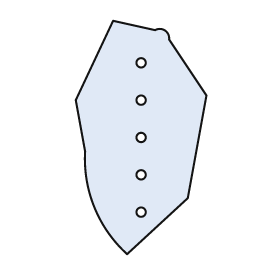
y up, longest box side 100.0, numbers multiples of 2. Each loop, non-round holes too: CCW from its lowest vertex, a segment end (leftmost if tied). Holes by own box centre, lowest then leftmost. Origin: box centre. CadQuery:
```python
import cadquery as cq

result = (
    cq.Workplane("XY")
    .moveTo(-6.0, -50.0)
    .lineTo(20.0, -26.0)
    .lineTo(28.0, 18.0)
    .lineTo(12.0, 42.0)
    .threePointArc((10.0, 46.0), (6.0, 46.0))
    .lineTo(-12.0, 50.0)
    .lineTo(-28.0, 16.0)
    .lineTo(-24.0, -6.0)
    .threePointArc((-20.0, -30.0), (-6.0, -50.0))
    .close()
    .moveTo(0.0, -32.0)
    .circle(2.0)
    .moveTo(0.0, -16.0)
    .circle(2.0)
    .moveTo(0.0, 0.0)
    .circle(2.0)
    .moveTo(0.0, 16.0)
    .circle(2.0)
    .moveTo(0.0, 32.0)
    .circle(2.0)
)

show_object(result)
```